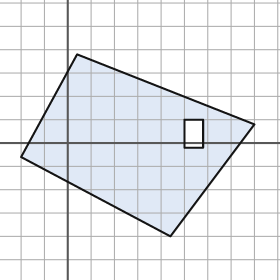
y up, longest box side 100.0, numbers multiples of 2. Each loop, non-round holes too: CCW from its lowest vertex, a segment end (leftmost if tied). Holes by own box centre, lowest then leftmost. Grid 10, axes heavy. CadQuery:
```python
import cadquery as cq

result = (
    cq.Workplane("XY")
    .moveTo(44.0, -40.0)
    .lineTo(80.0, 8.0)
    .lineTo(4.0, 38.0)
    .lineTo(-20.0, -6.0)
    .close()
    .moveTo(50.0, -2.0)
    .lineTo(58.0, -2.0)
    .lineTo(58.0, 10.0)
    .lineTo(50.0, 10.0)
    .close()
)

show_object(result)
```